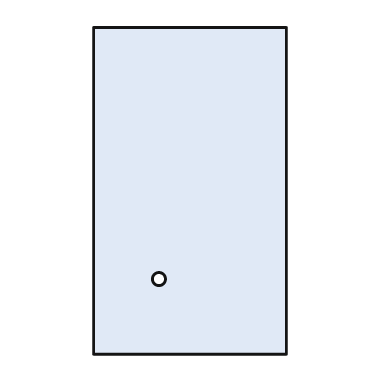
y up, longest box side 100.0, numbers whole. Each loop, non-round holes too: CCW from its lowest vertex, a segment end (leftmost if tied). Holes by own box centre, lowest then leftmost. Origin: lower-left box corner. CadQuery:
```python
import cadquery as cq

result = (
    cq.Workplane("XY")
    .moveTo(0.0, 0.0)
    .lineTo(59.0, 0.0)
    .lineTo(59.0, 100.0)
    .lineTo(0.0, 100.0)
    .close()
    .moveTo(20.0, 23.0)
    .circle(2.0)
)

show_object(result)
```